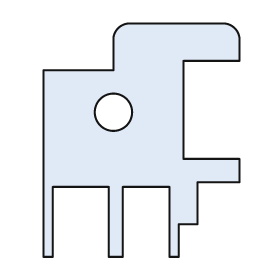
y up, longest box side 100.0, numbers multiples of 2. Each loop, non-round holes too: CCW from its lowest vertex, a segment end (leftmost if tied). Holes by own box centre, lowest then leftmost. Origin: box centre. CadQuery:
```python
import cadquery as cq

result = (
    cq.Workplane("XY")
    .moveTo(-42.0, -50.0)
    .lineTo(-38.0, -50.0)
    .lineTo(-38.0, -20.0)
    .lineTo(-14.0, -20.0)
    .lineTo(-14.0, -50.0)
    .lineTo(-8.0, -50.0)
    .lineTo(-8.0, -20.0)
    .lineTo(12.0, -20.0)
    .lineTo(12.0, -50.0)
    .lineTo(16.0, -50.0)
    .lineTo(16.0, -36.0)
    .lineTo(24.0, -36.0)
    .lineTo(24.0, -18.0)
    .lineTo(42.0, -18.0)
    .lineTo(42.0, -8.0)
    .lineTo(18.0, -8.0)
    .lineTo(18.0, 34.0)
    .lineTo(42.0, 34.0)
    .lineTo(42.0, 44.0)
    .threePointArc((40.0, 48.0), (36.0, 50.0))
    .lineTo(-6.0, 50.0)
    .threePointArc((-10.0, 48.0), (-12.0, 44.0))
    .lineTo(-12.0, 30.0)
    .lineTo(-42.0, 30.0)
    .close()
    .moveTo(-12.0, 12.0)
    .circle(8.0)
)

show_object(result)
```